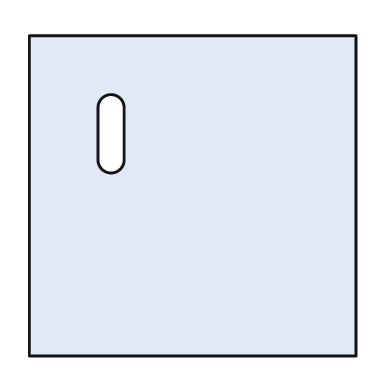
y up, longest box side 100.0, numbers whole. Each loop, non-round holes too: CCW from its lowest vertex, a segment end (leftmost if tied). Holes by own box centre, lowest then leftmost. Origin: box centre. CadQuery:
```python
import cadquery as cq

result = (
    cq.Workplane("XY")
    .moveTo(-50.0, -49.0)
    .lineTo(50.0, -49.0)
    .lineTo(50.0, 49.0)
    .lineTo(-50.0, 49.0)
    .close()
    .moveTo(-29.0, 11.0)
    .threePointArc((-25.0, 7.0), (-21.0, 11.0))
    .lineTo(-21.0, 27.0)
    .threePointArc((-25.0, 31.0), (-29.0, 27.0))
    .close()
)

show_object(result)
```